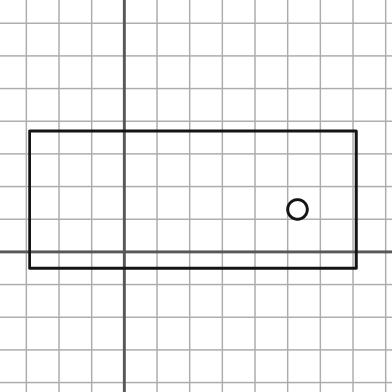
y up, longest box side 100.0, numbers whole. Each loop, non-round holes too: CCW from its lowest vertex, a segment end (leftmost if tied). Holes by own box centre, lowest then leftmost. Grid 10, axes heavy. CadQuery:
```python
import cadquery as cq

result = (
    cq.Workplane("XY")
    .moveTo(-29.0, -5.0)
    .lineTo(71.0, -5.0)
    .lineTo(71.0, 37.0)
    .lineTo(-29.0, 37.0)
    .close()
    .moveTo(53.0, 13.0)
    .circle(3.0)
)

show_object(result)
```